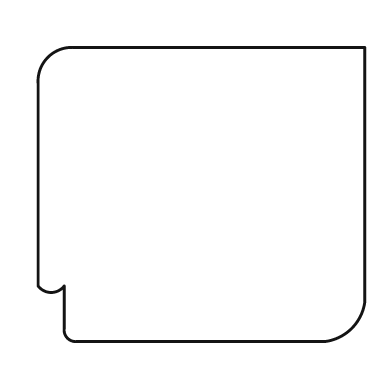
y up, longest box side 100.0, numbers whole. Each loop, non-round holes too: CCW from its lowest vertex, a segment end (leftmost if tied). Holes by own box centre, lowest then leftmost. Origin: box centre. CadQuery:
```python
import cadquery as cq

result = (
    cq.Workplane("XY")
    .moveTo(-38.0, -45.0)
    .lineTo(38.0, -45.0)
    .threePointArc((46.0, -41.0), (50.0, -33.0))
    .lineTo(50.0, 45.0)
    .lineTo(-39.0, 45.0)
    .threePointArc((-47.0, 42.0), (-50.0, 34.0))
    .lineTo(-50.0, -28.0)
    .threePointArc((-46.0, -30.0), (-42.0, -28.0))
    .lineTo(-42.0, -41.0)
    .threePointArc((-41.0, -44.0), (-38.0, -45.0))
    .close()
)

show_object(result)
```